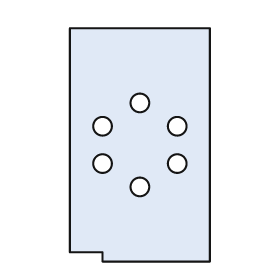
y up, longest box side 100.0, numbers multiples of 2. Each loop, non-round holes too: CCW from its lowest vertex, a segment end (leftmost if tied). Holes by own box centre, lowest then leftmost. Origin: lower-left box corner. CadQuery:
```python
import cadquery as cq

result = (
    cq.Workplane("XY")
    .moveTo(14.0, 0.0)
    .lineTo(60.0, 0.0)
    .lineTo(60.0, 100.0)
    .lineTo(0.0, 100.0)
    .lineTo(0.0, 4.0)
    .lineTo(14.0, 4.0)
    .close()
    .moveTo(30.0, 32.0)
    .circle(4.0)
    .moveTo(14.0, 42.0)
    .circle(4.0)
    .moveTo(46.0, 42.0)
    .circle(4.0)
    .moveTo(14.0, 58.0)
    .circle(4.0)
    .moveTo(46.0, 58.0)
    .circle(4.0)
    .moveTo(30.0, 68.0)
    .circle(4.0)
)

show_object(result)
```